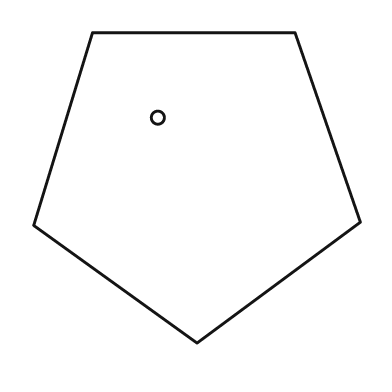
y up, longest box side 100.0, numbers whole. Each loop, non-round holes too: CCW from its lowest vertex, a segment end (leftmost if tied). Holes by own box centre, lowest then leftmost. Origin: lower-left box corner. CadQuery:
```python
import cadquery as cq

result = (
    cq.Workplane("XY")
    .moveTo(50.0, 0.0)
    .lineTo(100.0, 37.0)
    .lineTo(80.0, 95.0)
    .lineTo(18.0, 95.0)
    .lineTo(0.0, 36.0)
    .close()
    .moveTo(38.0, 69.0)
    .circle(2.0)
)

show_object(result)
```